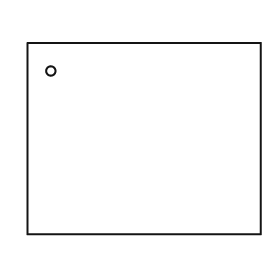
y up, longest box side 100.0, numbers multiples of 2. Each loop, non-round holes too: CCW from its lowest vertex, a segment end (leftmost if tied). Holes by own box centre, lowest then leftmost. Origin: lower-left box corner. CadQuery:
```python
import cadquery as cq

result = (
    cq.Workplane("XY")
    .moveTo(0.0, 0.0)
    .lineTo(100.0, 0.0)
    .lineTo(100.0, 82.0)
    .lineTo(0.0, 82.0)
    .close()
    .moveTo(10.0, 70.0)
    .circle(2.0)
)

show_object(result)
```